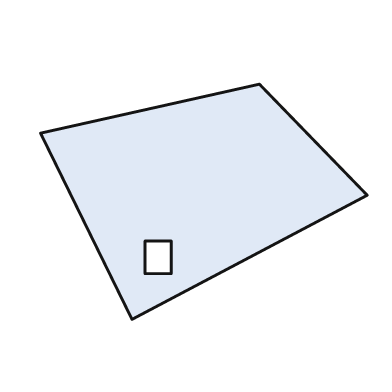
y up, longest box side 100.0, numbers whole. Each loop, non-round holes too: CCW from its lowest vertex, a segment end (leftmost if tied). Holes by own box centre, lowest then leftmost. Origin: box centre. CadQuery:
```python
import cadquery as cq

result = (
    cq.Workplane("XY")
    .moveTo(-22.0, -36.0)
    .lineTo(50.0, 2.0)
    .lineTo(17.0, 36.0)
    .lineTo(-50.0, 21.0)
    .close()
    .moveTo(-18.0, -22.0)
    .lineTo(-10.0, -22.0)
    .lineTo(-10.0, -12.0)
    .lineTo(-18.0, -12.0)
    .close()
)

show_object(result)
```